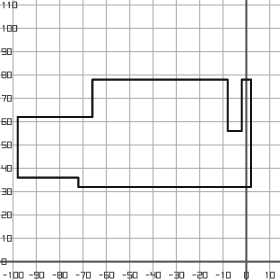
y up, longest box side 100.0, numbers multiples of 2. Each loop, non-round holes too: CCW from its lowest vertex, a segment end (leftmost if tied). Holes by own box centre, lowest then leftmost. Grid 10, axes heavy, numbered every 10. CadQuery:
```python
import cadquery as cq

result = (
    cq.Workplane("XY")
    .moveTo(-72.0, 32.0)
    .lineTo(2.0, 32.0)
    .lineTo(2.0, 78.0)
    .lineTo(-2.0, 78.0)
    .lineTo(-2.0, 56.0)
    .lineTo(-8.0, 56.0)
    .lineTo(-8.0, 78.0)
    .lineTo(-66.0, 78.0)
    .lineTo(-66.0, 62.0)
    .lineTo(-98.0, 62.0)
    .lineTo(-98.0, 36.0)
    .lineTo(-72.0, 36.0)
    .close()
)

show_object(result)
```